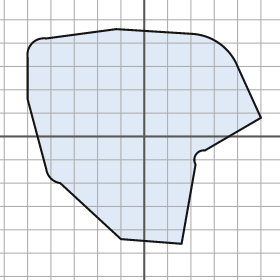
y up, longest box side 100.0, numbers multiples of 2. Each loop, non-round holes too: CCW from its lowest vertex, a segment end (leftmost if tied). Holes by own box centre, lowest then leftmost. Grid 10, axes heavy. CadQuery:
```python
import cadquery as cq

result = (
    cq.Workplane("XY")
    .moveTo(16.0, -46.0)
    .lineTo(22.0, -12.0)
    .threePointArc((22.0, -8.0), (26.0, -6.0))
    .lineTo(50.0, 8.0)
    .lineTo(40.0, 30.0)
    .threePointArc((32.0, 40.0), (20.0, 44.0))
    .lineTo(-12.0, 46.0)
    .lineTo(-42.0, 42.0)
    .threePointArc((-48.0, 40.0), (-50.0, 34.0))
    .lineTo(-50.0, 16.0)
    .lineTo(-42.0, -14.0)
    .threePointArc((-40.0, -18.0), (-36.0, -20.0))
    .lineTo(-10.0, -44.0)
    .close()
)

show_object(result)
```